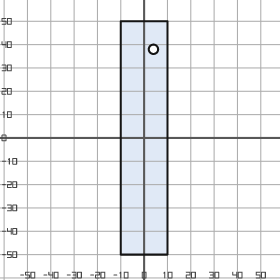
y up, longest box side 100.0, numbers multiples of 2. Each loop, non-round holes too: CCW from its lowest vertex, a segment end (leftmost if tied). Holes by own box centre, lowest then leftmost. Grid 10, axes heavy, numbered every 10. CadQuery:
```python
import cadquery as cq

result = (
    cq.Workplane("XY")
    .moveTo(-10.0, -50.0)
    .lineTo(10.0, -50.0)
    .lineTo(10.0, 50.0)
    .lineTo(-10.0, 50.0)
    .close()
    .moveTo(4.0, 38.0)
    .circle(2.0)
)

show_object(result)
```